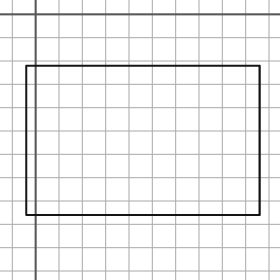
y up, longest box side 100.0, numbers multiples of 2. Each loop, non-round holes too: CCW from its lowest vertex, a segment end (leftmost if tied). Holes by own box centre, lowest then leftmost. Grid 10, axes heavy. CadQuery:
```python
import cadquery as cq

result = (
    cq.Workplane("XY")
    .moveTo(-4.0, -86.0)
    .lineTo(96.0, -86.0)
    .lineTo(96.0, -22.0)
    .lineTo(-4.0, -22.0)
    .close()
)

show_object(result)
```